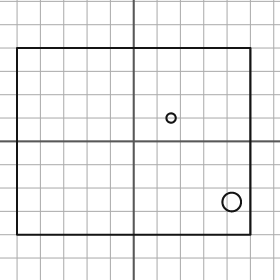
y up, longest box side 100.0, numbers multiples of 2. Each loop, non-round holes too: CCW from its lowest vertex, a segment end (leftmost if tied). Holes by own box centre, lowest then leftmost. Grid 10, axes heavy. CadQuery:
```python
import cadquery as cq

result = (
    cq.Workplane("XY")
    .moveTo(-50.0, -40.0)
    .lineTo(50.0, -40.0)
    .lineTo(50.0, 40.0)
    .lineTo(-50.0, 40.0)
    .close()
    .moveTo(42.0, -26.0)
    .circle(4.0)
    .moveTo(16.0, 10.0)
    .circle(2.0)
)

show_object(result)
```